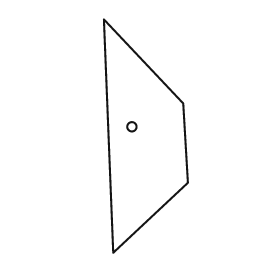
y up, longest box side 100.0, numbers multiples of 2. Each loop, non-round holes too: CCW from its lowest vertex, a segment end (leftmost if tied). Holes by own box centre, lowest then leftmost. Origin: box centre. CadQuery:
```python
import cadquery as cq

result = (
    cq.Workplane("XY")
    .moveTo(-14.0, -50.0)
    .lineTo(18.0, -20.0)
    .lineTo(16.0, 14.0)
    .lineTo(-18.0, 50.0)
    .close()
    .moveTo(-6.0, 4.0)
    .circle(2.0)
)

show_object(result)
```